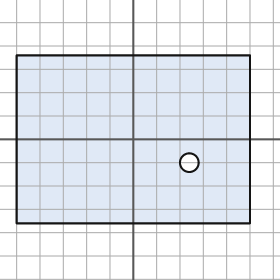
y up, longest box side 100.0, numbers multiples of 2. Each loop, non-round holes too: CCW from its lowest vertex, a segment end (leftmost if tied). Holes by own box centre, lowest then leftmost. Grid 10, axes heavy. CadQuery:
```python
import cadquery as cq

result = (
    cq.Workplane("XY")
    .moveTo(-50.0, -36.0)
    .lineTo(50.0, -36.0)
    .lineTo(50.0, 36.0)
    .lineTo(-50.0, 36.0)
    .close()
    .moveTo(24.0, -10.0)
    .circle(4.0)
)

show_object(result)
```